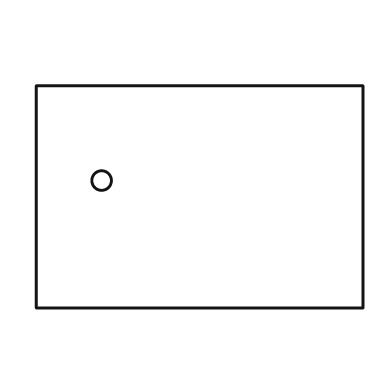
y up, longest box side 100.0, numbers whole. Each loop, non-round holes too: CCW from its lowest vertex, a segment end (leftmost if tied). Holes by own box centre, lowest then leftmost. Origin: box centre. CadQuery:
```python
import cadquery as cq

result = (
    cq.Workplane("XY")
    .moveTo(-50.0, -34.0)
    .lineTo(50.0, -34.0)
    .lineTo(50.0, 34.0)
    .lineTo(-50.0, 34.0)
    .close()
    .moveTo(-30.0, 5.0)
    .circle(3.0)
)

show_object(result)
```